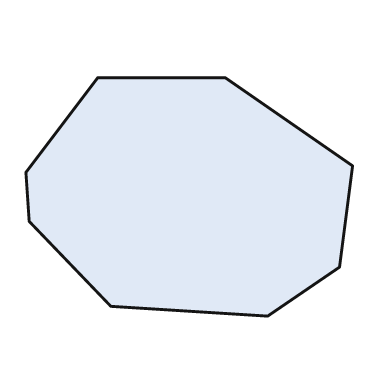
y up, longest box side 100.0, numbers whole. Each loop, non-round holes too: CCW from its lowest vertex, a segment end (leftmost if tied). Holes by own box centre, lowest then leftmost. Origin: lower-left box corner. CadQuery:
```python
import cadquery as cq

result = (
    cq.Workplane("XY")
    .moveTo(74.0, 0.0)
    .lineTo(96.0, 15.0)
    .lineTo(100.0, 46.0)
    .lineTo(61.0, 73.0)
    .lineTo(22.0, 73.0)
    .lineTo(0.0, 44.0)
    .lineTo(1.0, 29.0)
    .lineTo(26.0, 3.0)
    .close()
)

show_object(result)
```